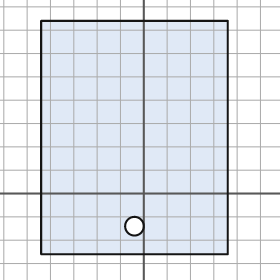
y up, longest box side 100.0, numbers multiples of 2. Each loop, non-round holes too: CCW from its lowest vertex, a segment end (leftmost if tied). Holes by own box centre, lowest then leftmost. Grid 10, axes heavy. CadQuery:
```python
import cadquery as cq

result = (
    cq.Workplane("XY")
    .moveTo(-44.0, -26.0)
    .lineTo(36.0, -26.0)
    .lineTo(36.0, 74.0)
    .lineTo(-44.0, 74.0)
    .close()
    .moveTo(-4.0, -14.0)
    .circle(4.0)
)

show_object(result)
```